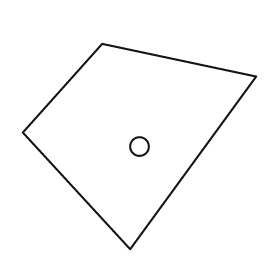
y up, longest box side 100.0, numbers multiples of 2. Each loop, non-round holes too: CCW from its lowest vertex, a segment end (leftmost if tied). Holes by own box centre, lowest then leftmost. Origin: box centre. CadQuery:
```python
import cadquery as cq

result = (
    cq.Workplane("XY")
    .moveTo(-4.0, -44.0)
    .lineTo(50.0, 30.0)
    .lineTo(-16.0, 44.0)
    .lineTo(-50.0, 6.0)
    .close()
    .moveTo(0.0, 0.0)
    .circle(4.0)
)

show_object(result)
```